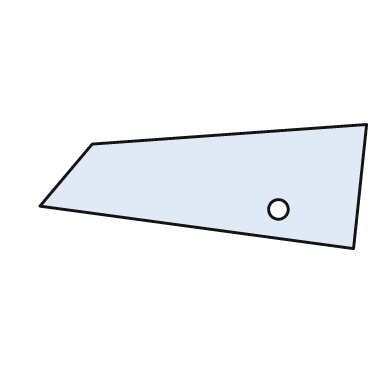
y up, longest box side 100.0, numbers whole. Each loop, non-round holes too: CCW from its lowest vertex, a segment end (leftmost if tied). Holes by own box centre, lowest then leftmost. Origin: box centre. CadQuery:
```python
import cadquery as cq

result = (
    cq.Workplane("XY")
    .moveTo(46.0, -19.0)
    .lineTo(50.0, 19.0)
    .lineTo(-34.0, 13.0)
    .lineTo(-50.0, -6.0)
    .close()
    .moveTo(23.0, -7.0)
    .circle(3.0)
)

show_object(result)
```